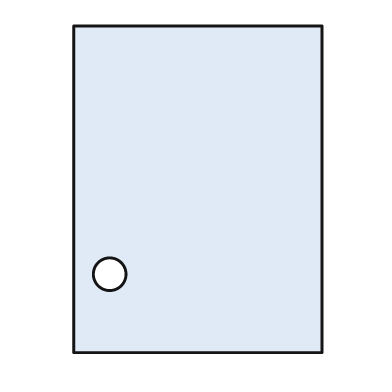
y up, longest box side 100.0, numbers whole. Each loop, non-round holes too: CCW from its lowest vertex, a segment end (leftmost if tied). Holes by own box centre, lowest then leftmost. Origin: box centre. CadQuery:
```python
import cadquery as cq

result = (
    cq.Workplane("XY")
    .moveTo(-38.0, -50.0)
    .lineTo(38.0, -50.0)
    .lineTo(38.0, 50.0)
    .lineTo(-38.0, 50.0)
    .close()
    .moveTo(-27.0, -26.0)
    .circle(5.0)
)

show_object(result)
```